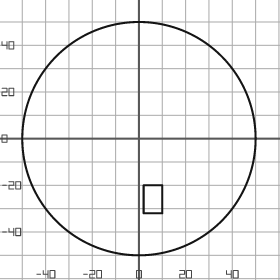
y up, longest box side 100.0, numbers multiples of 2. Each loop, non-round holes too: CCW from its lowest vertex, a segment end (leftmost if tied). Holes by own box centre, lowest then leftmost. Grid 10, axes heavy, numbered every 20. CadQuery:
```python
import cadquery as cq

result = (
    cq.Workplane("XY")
    .moveTo(0.0, 0.0)
    .circle(50.0)
    .moveTo(2.0, -32.0)
    .lineTo(10.0, -32.0)
    .lineTo(10.0, -20.0)
    .lineTo(2.0, -20.0)
    .close()
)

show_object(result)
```